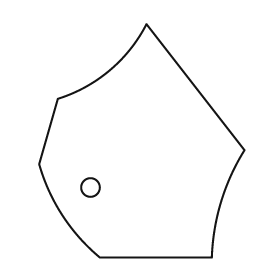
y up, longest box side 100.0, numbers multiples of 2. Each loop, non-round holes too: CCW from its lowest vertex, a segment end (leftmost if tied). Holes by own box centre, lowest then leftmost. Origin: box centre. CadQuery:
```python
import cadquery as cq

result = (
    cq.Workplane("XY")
    .moveTo(-18.0, -50.0)
    .lineTo(30.0, -50.0)
    .threePointArc((34.0, -26.0), (44.0, -4.0))
    .lineTo(2.0, 50.0)
    .threePointArc((-14.0, 30.0), (-36.0, 18.0))
    .lineTo(-44.0, -10.0)
    .threePointArc((-34.0, -32.0), (-18.0, -50.0))
    .close()
    .moveTo(-22.0, -20.0)
    .circle(4.0)
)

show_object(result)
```